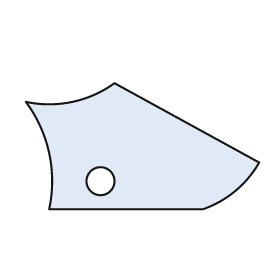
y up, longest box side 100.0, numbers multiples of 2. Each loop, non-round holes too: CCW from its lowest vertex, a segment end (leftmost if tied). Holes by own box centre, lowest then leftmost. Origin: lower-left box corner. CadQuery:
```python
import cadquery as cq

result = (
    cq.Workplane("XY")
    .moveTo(10.0, 0.0)
    .lineTo(76.0, 0.0)
    .threePointArc((90.0, 8.0), (100.0, 20.0))
    .lineTo(38.0, 54.0)
    .threePointArc((20.0, 46.0), (0.0, 46.0))
    .threePointArc((10.0, 24.0), (10.0, 0.0))
    .close()
    .moveTo(32.0, 12.0)
    .circle(6.0)
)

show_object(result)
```